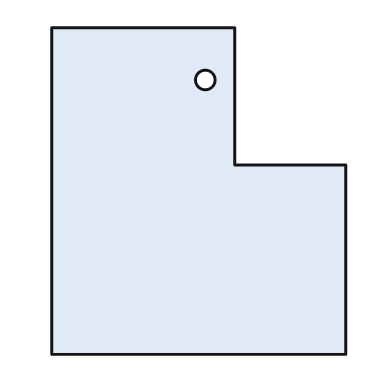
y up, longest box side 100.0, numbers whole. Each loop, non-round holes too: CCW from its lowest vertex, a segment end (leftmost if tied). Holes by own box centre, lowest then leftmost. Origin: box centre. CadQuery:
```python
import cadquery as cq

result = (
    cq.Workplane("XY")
    .moveTo(-45.0, -50.0)
    .lineTo(45.0, -50.0)
    .lineTo(45.0, 8.0)
    .lineTo(11.0, 8.0)
    .lineTo(11.0, 50.0)
    .lineTo(-45.0, 50.0)
    .close()
    .moveTo(2.0, 34.0)
    .circle(3.0)
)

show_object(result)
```